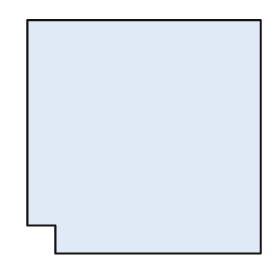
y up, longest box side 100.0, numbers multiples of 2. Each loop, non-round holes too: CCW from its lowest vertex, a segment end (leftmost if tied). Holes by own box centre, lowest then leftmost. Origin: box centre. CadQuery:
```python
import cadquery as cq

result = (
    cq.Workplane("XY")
    .moveTo(-38.0, -50.0)
    .lineTo(50.0, -50.0)
    .lineTo(50.0, 50.0)
    .lineTo(-50.0, 50.0)
    .lineTo(-50.0, -38.0)
    .lineTo(-38.0, -38.0)
    .close()
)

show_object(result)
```